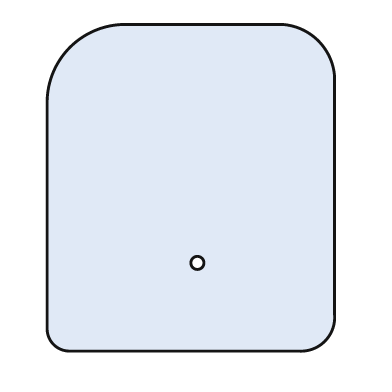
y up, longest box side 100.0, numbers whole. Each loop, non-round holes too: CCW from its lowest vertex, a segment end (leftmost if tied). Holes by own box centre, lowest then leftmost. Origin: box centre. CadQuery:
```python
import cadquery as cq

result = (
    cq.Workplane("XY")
    .moveTo(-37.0, -50.0)
    .lineTo(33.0, -50.0)
    .threePointArc((41.0, -47.0), (44.0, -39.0))
    .lineTo(44.0, 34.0)
    .threePointArc((39.0, 45.0), (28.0, 50.0))
    .lineTo(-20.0, 50.0)
    .threePointArc((-37.0, 43.0), (-44.0, 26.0))
    .lineTo(-44.0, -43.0)
    .threePointArc((-42.0, -48.0), (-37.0, -50.0))
    .close()
    .moveTo(2.0, -23.0)
    .circle(2.0)
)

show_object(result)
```